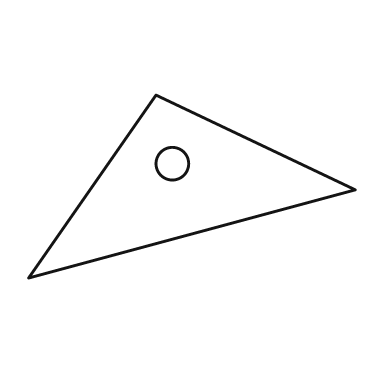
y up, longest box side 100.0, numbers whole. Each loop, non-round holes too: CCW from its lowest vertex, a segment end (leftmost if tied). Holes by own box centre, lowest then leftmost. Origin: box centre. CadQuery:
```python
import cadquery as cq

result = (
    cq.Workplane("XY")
    .moveTo(-50.0, -28.0)
    .lineTo(50.0, -1.0)
    .lineTo(-11.0, 28.0)
    .close()
    .moveTo(-6.0, 7.0)
    .circle(5.0)
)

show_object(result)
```